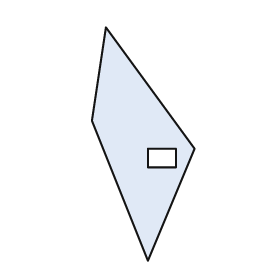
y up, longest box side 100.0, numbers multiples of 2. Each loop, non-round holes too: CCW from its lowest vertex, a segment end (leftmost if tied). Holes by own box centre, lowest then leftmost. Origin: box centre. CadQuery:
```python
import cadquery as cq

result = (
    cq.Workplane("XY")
    .moveTo(2.0, -50.0)
    .lineTo(22.0, -2.0)
    .lineTo(-16.0, 50.0)
    .lineTo(-22.0, 10.0)
    .close()
    .moveTo(2.0, -10.0)
    .lineTo(14.0, -10.0)
    .lineTo(14.0, -2.0)
    .lineTo(2.0, -2.0)
    .close()
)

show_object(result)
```